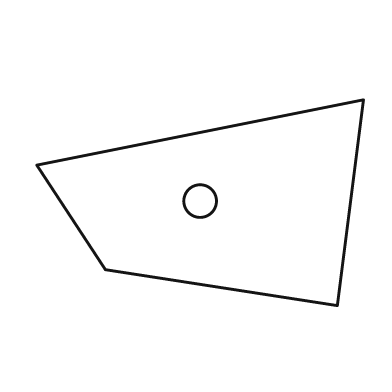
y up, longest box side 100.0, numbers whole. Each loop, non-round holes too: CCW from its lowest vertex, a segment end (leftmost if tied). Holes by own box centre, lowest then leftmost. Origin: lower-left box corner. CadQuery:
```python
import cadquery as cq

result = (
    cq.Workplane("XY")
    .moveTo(92.0, 0.0)
    .lineTo(100.0, 63.0)
    .lineTo(0.0, 43.0)
    .lineTo(21.0, 11.0)
    .close()
    .moveTo(50.0, 32.0)
    .circle(5.0)
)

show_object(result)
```